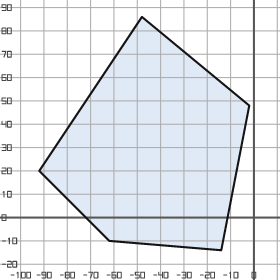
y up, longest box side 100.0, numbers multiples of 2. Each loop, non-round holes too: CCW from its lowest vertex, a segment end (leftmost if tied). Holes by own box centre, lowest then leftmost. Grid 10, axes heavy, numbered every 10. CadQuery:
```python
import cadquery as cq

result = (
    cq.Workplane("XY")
    .moveTo(-14.0, -14.0)
    .lineTo(-2.0, 48.0)
    .lineTo(-48.0, 86.0)
    .lineTo(-92.0, 20.0)
    .lineTo(-62.0, -10.0)
    .close()
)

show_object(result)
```